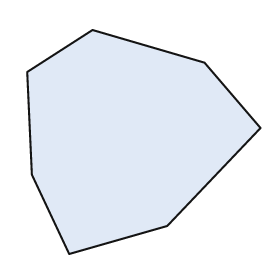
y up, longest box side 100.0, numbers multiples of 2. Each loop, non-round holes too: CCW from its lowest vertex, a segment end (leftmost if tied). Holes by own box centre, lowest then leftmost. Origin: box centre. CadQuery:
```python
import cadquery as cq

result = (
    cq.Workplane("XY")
    .moveTo(-32.0, -48.0)
    .lineTo(10.0, -36.0)
    .lineTo(50.0, 6.0)
    .lineTo(26.0, 34.0)
    .lineTo(-22.0, 48.0)
    .lineTo(-50.0, 30.0)
    .lineTo(-48.0, -14.0)
    .close()
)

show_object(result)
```